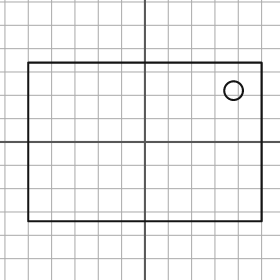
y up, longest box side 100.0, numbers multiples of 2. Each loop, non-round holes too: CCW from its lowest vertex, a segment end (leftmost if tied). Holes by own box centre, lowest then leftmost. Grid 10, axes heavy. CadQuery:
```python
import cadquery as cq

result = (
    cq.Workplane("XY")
    .moveTo(-50.0, -34.0)
    .lineTo(50.0, -34.0)
    .lineTo(50.0, 34.0)
    .lineTo(-50.0, 34.0)
    .close()
    .moveTo(38.0, 22.0)
    .circle(4.0)
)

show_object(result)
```